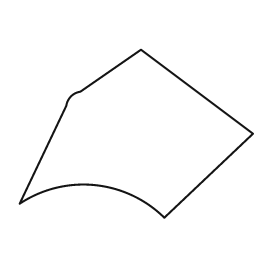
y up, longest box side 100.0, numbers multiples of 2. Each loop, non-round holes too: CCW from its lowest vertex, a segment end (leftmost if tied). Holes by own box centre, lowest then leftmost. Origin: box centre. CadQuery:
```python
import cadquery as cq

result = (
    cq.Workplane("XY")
    .moveTo(12.0, -36.0)
    .lineTo(50.0, 0.0)
    .lineTo(2.0, 36.0)
    .lineTo(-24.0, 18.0)
    .threePointArc((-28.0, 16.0), (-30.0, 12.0))
    .lineTo(-50.0, -30.0)
    .threePointArc((-18.0, -22.0), (12.0, -36.0))
    .close()
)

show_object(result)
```